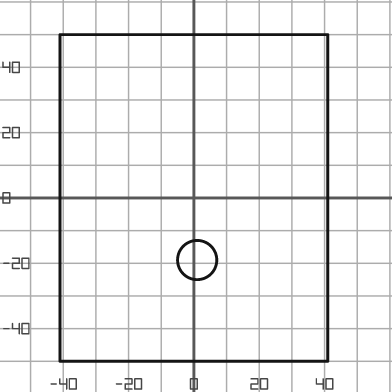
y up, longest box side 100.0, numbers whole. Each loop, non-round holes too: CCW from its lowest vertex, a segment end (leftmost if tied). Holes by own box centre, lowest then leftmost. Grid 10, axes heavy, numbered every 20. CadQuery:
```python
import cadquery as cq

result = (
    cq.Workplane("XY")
    .moveTo(-41.0, -50.0)
    .lineTo(41.0, -50.0)
    .lineTo(41.0, 50.0)
    .lineTo(-41.0, 50.0)
    .close()
    .moveTo(1.0, -19.0)
    .circle(6.0)
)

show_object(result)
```